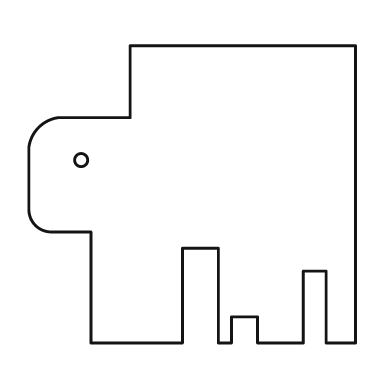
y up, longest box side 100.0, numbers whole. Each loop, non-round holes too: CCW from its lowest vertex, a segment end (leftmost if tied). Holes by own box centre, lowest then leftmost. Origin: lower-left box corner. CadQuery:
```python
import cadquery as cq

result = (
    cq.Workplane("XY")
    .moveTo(19.0, 0.0)
    .lineTo(47.0, 0.0)
    .lineTo(47.0, 29.0)
    .lineTo(58.0, 29.0)
    .lineTo(58.0, 0.0)
    .lineTo(62.0, 0.0)
    .lineTo(62.0, 8.0)
    .lineTo(70.0, 8.0)
    .lineTo(70.0, 0.0)
    .lineTo(84.0, 0.0)
    .lineTo(84.0, 22.0)
    .lineTo(91.0, 22.0)
    .lineTo(91.0, 0.0)
    .lineTo(100.0, 0.0)
    .lineTo(100.0, 91.0)
    .lineTo(31.0, 91.0)
    .lineTo(31.0, 69.0)
    .lineTo(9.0, 69.0)
    .threePointArc((3.0, 66.0), (0.0, 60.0))
    .lineTo(0.0, 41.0)
    .threePointArc((2.0, 36.0), (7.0, 34.0))
    .lineTo(19.0, 34.0)
    .close()
    .moveTo(16.0, 56.0)
    .circle(2.0)
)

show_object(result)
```